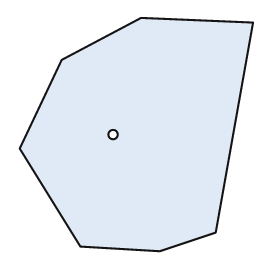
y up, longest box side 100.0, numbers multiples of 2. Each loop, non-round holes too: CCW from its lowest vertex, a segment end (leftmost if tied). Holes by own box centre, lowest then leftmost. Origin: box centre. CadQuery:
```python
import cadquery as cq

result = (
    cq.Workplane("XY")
    .moveTo(10.0, -50.0)
    .lineTo(34.0, -42.0)
    .lineTo(50.0, 48.0)
    .lineTo(2.0, 50.0)
    .lineTo(-32.0, 32.0)
    .lineTo(-50.0, -6.0)
    .lineTo(-24.0, -48.0)
    .close()
    .moveTo(-10.0, 0.0)
    .circle(2.0)
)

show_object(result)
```